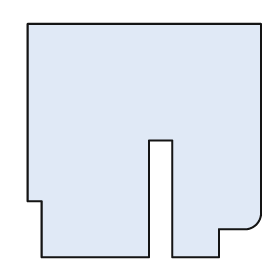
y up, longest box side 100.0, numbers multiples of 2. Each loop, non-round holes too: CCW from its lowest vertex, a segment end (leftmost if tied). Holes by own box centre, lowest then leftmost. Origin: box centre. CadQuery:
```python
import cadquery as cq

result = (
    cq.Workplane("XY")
    .moveTo(-44.0, -50.0)
    .lineTo(2.0, -50.0)
    .lineTo(2.0, 0.0)
    .lineTo(12.0, 0.0)
    .lineTo(12.0, -50.0)
    .lineTo(32.0, -50.0)
    .lineTo(32.0, -38.0)
    .lineTo(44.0, -38.0)
    .threePointArc((48.0, -36.0), (50.0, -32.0))
    .lineTo(50.0, 50.0)
    .lineTo(-50.0, 50.0)
    .lineTo(-50.0, -26.0)
    .lineTo(-44.0, -26.0)
    .close()
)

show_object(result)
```